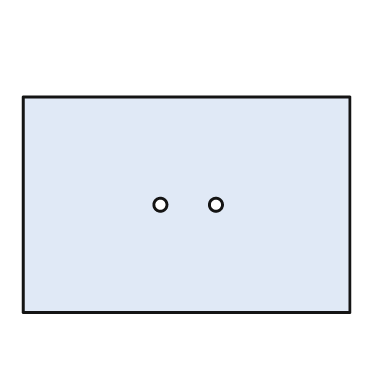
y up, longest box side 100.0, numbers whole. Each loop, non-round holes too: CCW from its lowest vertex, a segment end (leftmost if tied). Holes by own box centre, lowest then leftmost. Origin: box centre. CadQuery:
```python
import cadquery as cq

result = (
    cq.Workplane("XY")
    .moveTo(-50.0, -33.0)
    .lineTo(50.0, -33.0)
    .lineTo(50.0, 33.0)
    .lineTo(-50.0, 33.0)
    .close()
    .moveTo(-8.0, 0.0)
    .circle(2.0)
    .moveTo(9.0, 0.0)
    .circle(2.0)
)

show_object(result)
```